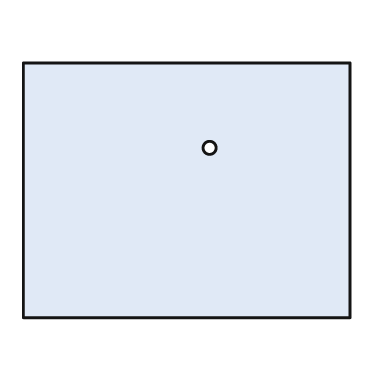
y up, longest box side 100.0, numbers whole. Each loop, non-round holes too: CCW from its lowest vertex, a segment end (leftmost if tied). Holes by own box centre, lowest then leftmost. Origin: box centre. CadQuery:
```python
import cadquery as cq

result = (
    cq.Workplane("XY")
    .moveTo(-50.0, -39.0)
    .lineTo(50.0, -39.0)
    .lineTo(50.0, 39.0)
    .lineTo(-50.0, 39.0)
    .close()
    .moveTo(7.0, 13.0)
    .circle(2.0)
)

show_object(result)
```